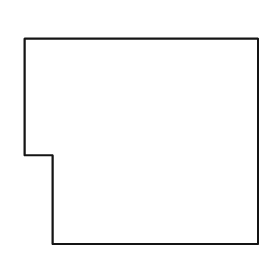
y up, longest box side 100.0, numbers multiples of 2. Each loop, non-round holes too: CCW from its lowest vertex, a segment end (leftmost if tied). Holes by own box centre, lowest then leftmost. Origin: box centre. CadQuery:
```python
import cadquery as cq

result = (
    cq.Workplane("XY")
    .moveTo(-38.0, -44.0)
    .lineTo(50.0, -44.0)
    .lineTo(50.0, 44.0)
    .lineTo(-50.0, 44.0)
    .lineTo(-50.0, -6.0)
    .lineTo(-38.0, -6.0)
    .close()
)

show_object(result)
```